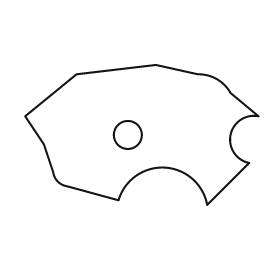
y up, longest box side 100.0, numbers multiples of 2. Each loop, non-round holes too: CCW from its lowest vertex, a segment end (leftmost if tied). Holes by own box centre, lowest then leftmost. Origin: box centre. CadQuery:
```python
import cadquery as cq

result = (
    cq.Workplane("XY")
    .moveTo(28.0, -30.0)
    .lineTo(46.0, -12.0)
    .threePointArc((38.0, 0.0), (50.0, 8.0))
    .lineTo(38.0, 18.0)
    .threePointArc((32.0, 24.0), (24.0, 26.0))
    .lineTo(6.0, 30.0)
    .lineTo(-28.0, 26.0)
    .lineTo(-50.0, 8.0)
    .lineTo(-42.0, -4.0)
    .lineTo(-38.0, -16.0)
    .threePointArc((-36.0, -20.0), (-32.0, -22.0))
    .lineTo(-10.0, -28.0)
    .threePointArc((10.0, -14.0), (28.0, -30.0))
    .close()
    .moveTo(-6.0, 0.0)
    .circle(6.0)
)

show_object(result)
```